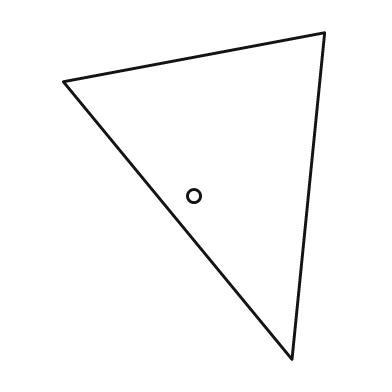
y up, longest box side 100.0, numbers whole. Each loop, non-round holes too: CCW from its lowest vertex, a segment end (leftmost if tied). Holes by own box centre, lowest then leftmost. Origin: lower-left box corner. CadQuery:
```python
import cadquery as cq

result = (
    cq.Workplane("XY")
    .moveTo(70.0, 0.0)
    .lineTo(80.0, 100.0)
    .lineTo(0.0, 85.0)
    .close()
    .moveTo(40.0, 50.0)
    .circle(2.0)
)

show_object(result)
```